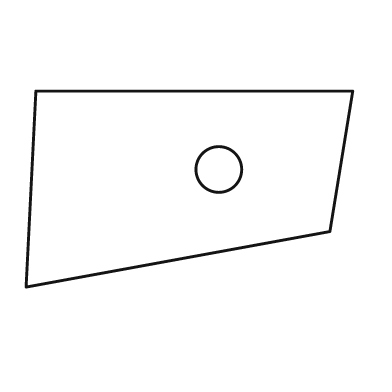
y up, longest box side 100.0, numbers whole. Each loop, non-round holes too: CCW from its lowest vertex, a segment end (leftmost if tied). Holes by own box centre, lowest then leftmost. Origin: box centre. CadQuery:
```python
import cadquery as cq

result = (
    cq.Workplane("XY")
    .moveTo(-50.0, -30.0)
    .lineTo(43.0, -13.0)
    .lineTo(50.0, 30.0)
    .lineTo(-47.0, 30.0)
    .close()
    .moveTo(9.0, 6.0)
    .circle(7.0)
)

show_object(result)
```